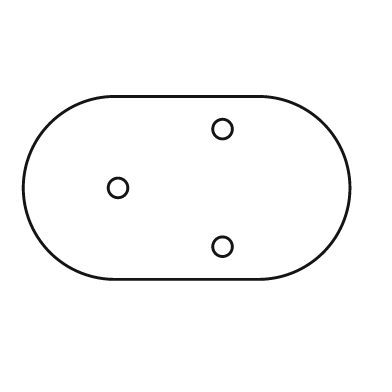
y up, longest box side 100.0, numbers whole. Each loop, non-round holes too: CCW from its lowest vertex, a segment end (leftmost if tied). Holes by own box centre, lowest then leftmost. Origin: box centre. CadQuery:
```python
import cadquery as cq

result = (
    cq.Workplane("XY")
    .moveTo(-22.0, -28.0)
    .lineTo(22.0, -28.0)
    .threePointArc((50.0, 0.0), (22.0, 28.0))
    .lineTo(-22.0, 28.0)
    .threePointArc((-50.0, 0.0), (-22.0, -28.0))
    .close()
    .moveTo(11.0, -18.0)
    .circle(3.0)
    .moveTo(-21.0, 0.0)
    .circle(3.0)
    .moveTo(11.0, 18.0)
    .circle(3.0)
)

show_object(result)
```